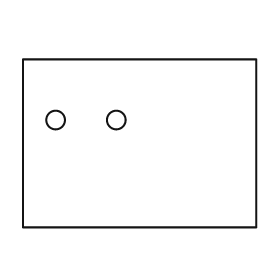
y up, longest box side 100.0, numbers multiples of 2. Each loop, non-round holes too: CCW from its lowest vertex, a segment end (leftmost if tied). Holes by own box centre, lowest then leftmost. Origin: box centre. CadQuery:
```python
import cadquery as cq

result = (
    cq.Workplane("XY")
    .moveTo(-50.0, -36.0)
    .lineTo(50.0, -36.0)
    .lineTo(50.0, 36.0)
    .lineTo(-50.0, 36.0)
    .close()
    .moveTo(-36.0, 10.0)
    .circle(4.0)
    .moveTo(-10.0, 10.0)
    .circle(4.0)
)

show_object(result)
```